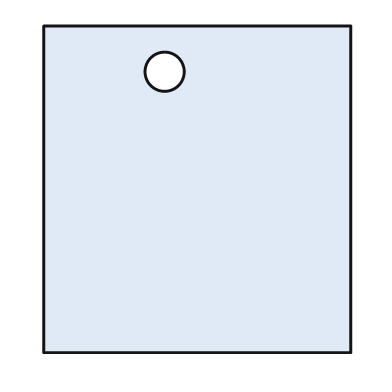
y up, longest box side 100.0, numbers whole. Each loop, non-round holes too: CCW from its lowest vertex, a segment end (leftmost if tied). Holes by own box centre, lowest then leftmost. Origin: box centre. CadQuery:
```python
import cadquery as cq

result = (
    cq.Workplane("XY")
    .moveTo(-47.0, -50.0)
    .lineTo(47.0, -50.0)
    .lineTo(47.0, 50.0)
    .lineTo(-47.0, 50.0)
    .close()
    .moveTo(-10.0, 36.0)
    .circle(6.0)
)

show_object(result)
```